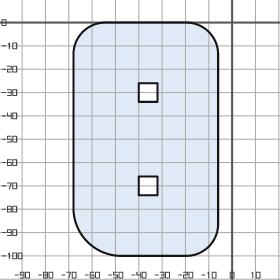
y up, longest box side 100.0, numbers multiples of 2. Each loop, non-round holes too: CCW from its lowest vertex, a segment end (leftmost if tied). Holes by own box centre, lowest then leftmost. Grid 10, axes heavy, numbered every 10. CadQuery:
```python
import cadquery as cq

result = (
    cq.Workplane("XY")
    .moveTo(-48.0, -100.0)
    .lineTo(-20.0, -100.0)
    .threePointArc((-10.0, -96.0), (-6.0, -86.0))
    .lineTo(-6.0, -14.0)
    .threePointArc((-10.0, -4.0), (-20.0, 0.0))
    .lineTo(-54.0, 0.0)
    .threePointArc((-64.0, -4.0), (-68.0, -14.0))
    .lineTo(-68.0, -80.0)
    .threePointArc((-62.0, -94.0), (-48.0, -100.0))
    .close()
    .moveTo(-40.0, -74.0)
    .lineTo(-32.0, -74.0)
    .lineTo(-32.0, -66.0)
    .lineTo(-40.0, -66.0)
    .close()
    .moveTo(-40.0, -34.0)
    .lineTo(-32.0, -34.0)
    .lineTo(-32.0, -26.0)
    .lineTo(-40.0, -26.0)
    .close()
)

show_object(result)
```